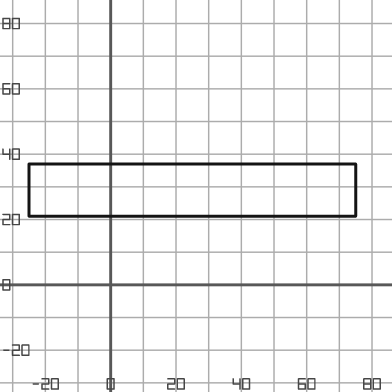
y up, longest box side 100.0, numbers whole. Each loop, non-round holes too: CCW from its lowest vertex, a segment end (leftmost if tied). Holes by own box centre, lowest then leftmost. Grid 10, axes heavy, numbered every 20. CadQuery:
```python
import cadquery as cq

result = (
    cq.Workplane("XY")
    .moveTo(-25.0, 21.0)
    .lineTo(75.0, 21.0)
    .lineTo(75.0, 37.0)
    .lineTo(-25.0, 37.0)
    .close()
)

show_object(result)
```